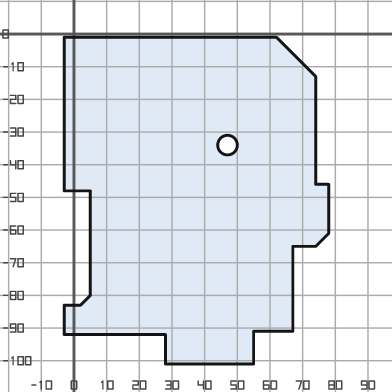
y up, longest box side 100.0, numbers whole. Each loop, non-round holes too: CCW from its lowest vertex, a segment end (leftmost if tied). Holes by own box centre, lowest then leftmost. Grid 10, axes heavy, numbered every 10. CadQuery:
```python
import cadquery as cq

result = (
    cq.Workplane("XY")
    .moveTo(28.0, -101.0)
    .lineTo(55.0, -101.0)
    .lineTo(55.0, -91.0)
    .lineTo(67.0, -91.0)
    .lineTo(67.0, -65.0)
    .lineTo(74.0, -65.0)
    .lineTo(78.0, -61.0)
    .lineTo(78.0, -46.0)
    .lineTo(74.0, -46.0)
    .lineTo(74.0, -13.0)
    .lineTo(62.0, -1.0)
    .lineTo(-3.0, -1.0)
    .lineTo(-3.0, -48.0)
    .lineTo(5.0, -48.0)
    .lineTo(5.0, -80.0)
    .lineTo(2.0, -83.0)
    .lineTo(-3.0, -83.0)
    .lineTo(-3.0, -92.0)
    .lineTo(28.0, -92.0)
    .close()
    .moveTo(47.0, -34.0)
    .circle(3.0)
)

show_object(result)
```